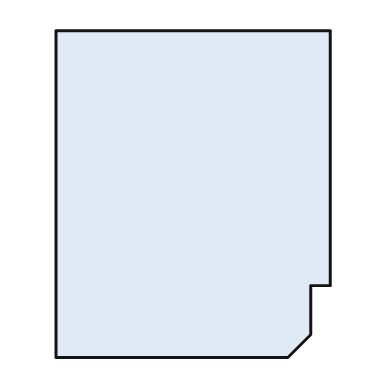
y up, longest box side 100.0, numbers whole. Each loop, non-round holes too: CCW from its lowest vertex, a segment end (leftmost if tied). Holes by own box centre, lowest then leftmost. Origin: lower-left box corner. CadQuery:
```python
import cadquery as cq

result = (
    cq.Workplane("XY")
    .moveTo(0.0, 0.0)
    .lineTo(71.0, 0.0)
    .lineTo(78.0, 7.0)
    .lineTo(78.0, 22.0)
    .lineTo(84.0, 22.0)
    .lineTo(84.0, 100.0)
    .lineTo(0.0, 100.0)
    .close()
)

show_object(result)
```